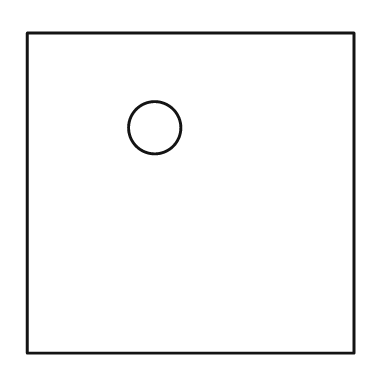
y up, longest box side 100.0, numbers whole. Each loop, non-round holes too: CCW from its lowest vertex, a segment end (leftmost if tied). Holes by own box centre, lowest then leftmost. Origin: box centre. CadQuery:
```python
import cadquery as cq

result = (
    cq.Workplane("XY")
    .moveTo(-50.0, -49.0)
    .lineTo(50.0, -49.0)
    .lineTo(50.0, 49.0)
    .lineTo(-50.0, 49.0)
    .close()
    .moveTo(-11.0, 20.0)
    .circle(8.0)
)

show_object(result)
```